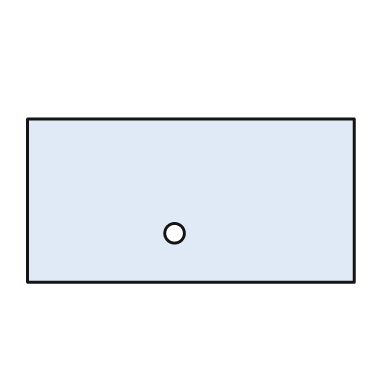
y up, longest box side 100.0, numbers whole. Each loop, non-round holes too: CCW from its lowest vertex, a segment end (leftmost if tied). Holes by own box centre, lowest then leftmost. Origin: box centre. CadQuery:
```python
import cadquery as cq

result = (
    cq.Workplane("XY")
    .moveTo(-50.0, -25.0)
    .lineTo(50.0, -25.0)
    .lineTo(50.0, 25.0)
    .lineTo(-50.0, 25.0)
    .close()
    .moveTo(-5.0, -10.0)
    .circle(3.0)
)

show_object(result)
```